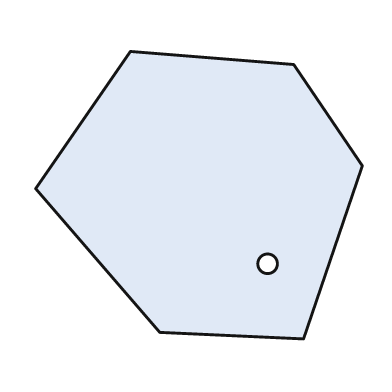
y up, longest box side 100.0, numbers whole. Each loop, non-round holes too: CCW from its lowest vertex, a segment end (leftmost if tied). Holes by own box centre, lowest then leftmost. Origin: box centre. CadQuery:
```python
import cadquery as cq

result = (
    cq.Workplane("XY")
    .moveTo(32.0, -44.0)
    .lineTo(50.0, 9.0)
    .lineTo(29.0, 40.0)
    .lineTo(-21.0, 44.0)
    .lineTo(-50.0, 2.0)
    .lineTo(-12.0, -42.0)
    .close()
    .moveTo(21.0, -21.0)
    .circle(3.0)
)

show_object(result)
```